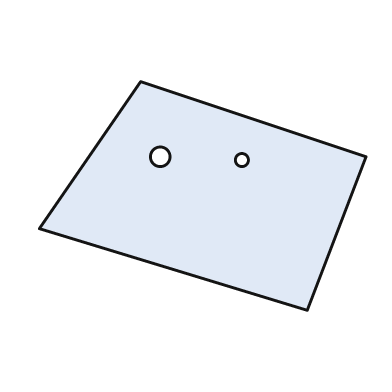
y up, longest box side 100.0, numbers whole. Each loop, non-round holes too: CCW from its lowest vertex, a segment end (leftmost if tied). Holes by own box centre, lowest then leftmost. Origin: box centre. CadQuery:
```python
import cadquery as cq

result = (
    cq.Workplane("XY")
    .moveTo(32.0, -35.0)
    .lineTo(50.0, 12.0)
    .lineTo(-19.0, 35.0)
    .lineTo(-50.0, -10.0)
    .close()
    .moveTo(12.0, 11.0)
    .circle(2.0)
    .moveTo(-13.0, 12.0)
    .circle(3.0)
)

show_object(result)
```